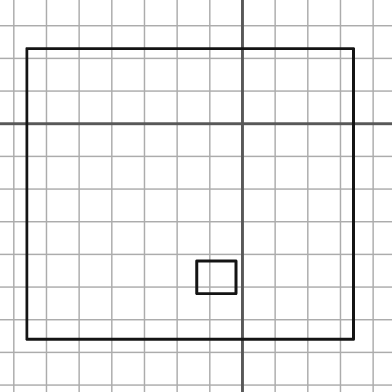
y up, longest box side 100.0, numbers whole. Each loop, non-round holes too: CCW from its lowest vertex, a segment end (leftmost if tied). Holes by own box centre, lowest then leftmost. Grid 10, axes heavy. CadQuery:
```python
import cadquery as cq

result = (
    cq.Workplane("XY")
    .moveTo(-66.0, -66.0)
    .lineTo(34.0, -66.0)
    .lineTo(34.0, 23.0)
    .lineTo(-66.0, 23.0)
    .close()
    .moveTo(-14.0, -52.0)
    .lineTo(-2.0, -52.0)
    .lineTo(-2.0, -42.0)
    .lineTo(-14.0, -42.0)
    .close()
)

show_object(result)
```